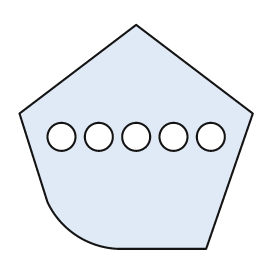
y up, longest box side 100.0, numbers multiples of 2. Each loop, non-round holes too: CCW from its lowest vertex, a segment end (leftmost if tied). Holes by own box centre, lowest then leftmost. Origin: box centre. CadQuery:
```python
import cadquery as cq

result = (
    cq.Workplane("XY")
    .moveTo(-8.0, -48.0)
    .lineTo(30.0, -48.0)
    .lineTo(50.0, 10.0)
    .lineTo(0.0, 48.0)
    .lineTo(-50.0, 10.0)
    .lineTo(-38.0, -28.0)
    .threePointArc((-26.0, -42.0), (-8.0, -48.0))
    .close()
    .moveTo(-32.0, 0.0)
    .circle(6.0)
    .moveTo(-16.0, 0.0)
    .circle(6.0)
    .moveTo(0.0, 0.0)
    .circle(6.0)
    .moveTo(16.0, 0.0)
    .circle(6.0)
    .moveTo(32.0, 0.0)
    .circle(6.0)
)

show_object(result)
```